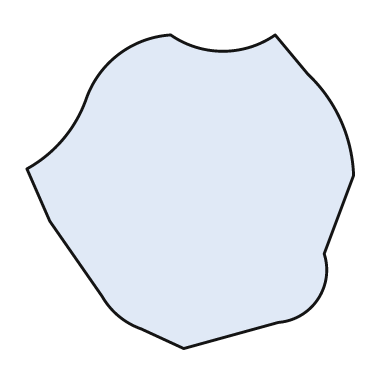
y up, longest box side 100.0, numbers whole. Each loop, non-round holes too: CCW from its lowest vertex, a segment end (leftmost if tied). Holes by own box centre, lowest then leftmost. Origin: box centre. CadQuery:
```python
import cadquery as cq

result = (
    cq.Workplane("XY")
    .moveTo(-2.0, -48.0)
    .lineTo(27.0, -40.0)
    .threePointArc((39.0, -33.0), (41.0, -19.0))
    .lineTo(50.0, 5.0)
    .threePointArc((46.0, 22.0), (36.0, 36.0))
    .lineTo(26.0, 48.0)
    .threePointArc((10.0, 43.0), (-6.0, 48.0))
    .threePointArc((-22.0, 42.0), (-32.0, 28.0))
    .threePointArc((-39.0, 16.0), (-50.0, 7.0))
    .lineTo(-43.0, -9.0)
    .lineTo(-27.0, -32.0)
    .threePointArc((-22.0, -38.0), (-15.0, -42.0))
    .close()
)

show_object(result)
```